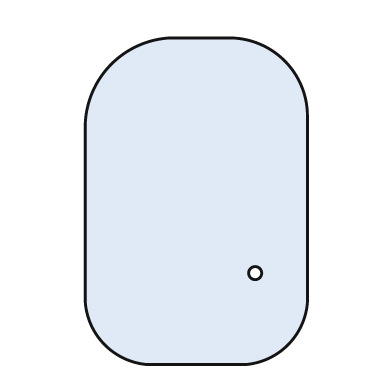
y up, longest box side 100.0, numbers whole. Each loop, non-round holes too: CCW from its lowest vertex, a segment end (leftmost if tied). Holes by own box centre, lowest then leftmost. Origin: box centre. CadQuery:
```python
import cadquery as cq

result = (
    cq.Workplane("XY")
    .moveTo(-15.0, -50.0)
    .lineTo(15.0, -50.0)
    .threePointArc((28.0, -44.0), (34.0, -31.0))
    .lineTo(34.0, 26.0)
    .threePointArc((27.0, 43.0), (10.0, 50.0))
    .lineTo(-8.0, 50.0)
    .threePointArc((-26.0, 42.0), (-34.0, 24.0))
    .lineTo(-34.0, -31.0)
    .threePointArc((-28.0, -44.0), (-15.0, -50.0))
    .close()
    .moveTo(18.0, -22.0)
    .circle(2.0)
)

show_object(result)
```